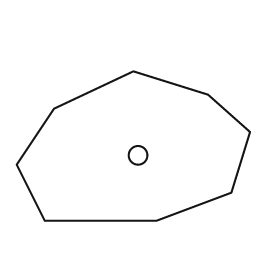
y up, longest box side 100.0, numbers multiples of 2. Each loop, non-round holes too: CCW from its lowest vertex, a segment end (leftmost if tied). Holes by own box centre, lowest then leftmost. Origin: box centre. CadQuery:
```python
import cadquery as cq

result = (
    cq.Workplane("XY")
    .moveTo(-38.0, -32.0)
    .lineTo(10.0, -32.0)
    .lineTo(42.0, -20.0)
    .lineTo(50.0, 6.0)
    .lineTo(32.0, 22.0)
    .lineTo(0.0, 32.0)
    .lineTo(-34.0, 16.0)
    .lineTo(-50.0, -8.0)
    .close()
    .moveTo(2.0, -4.0)
    .circle(4.0)
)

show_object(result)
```